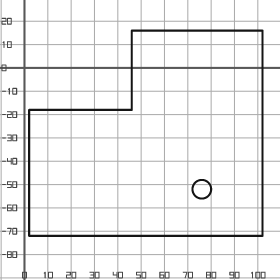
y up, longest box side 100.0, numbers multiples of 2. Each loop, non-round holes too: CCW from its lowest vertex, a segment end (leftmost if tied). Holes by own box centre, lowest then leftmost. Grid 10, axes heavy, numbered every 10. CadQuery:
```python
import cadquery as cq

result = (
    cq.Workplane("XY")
    .moveTo(2.0, -72.0)
    .lineTo(102.0, -72.0)
    .lineTo(102.0, 16.0)
    .lineTo(46.0, 16.0)
    .lineTo(46.0, -18.0)
    .lineTo(2.0, -18.0)
    .close()
    .moveTo(76.0, -52.0)
    .circle(4.0)
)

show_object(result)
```